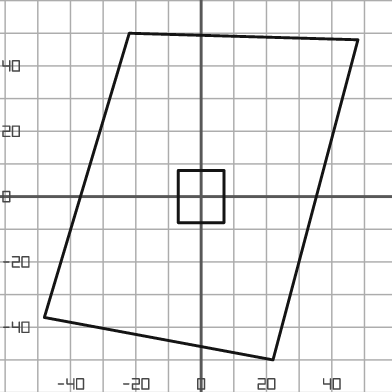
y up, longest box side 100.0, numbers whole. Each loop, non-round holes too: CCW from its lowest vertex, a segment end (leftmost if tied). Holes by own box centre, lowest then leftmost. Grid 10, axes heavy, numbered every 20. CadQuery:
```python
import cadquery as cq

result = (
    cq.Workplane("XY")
    .moveTo(22.0, -50.0)
    .lineTo(48.0, 48.0)
    .lineTo(-22.0, 50.0)
    .lineTo(-48.0, -37.0)
    .close()
    .moveTo(-7.0, -8.0)
    .lineTo(7.0, -8.0)
    .lineTo(7.0, 8.0)
    .lineTo(-7.0, 8.0)
    .close()
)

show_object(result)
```